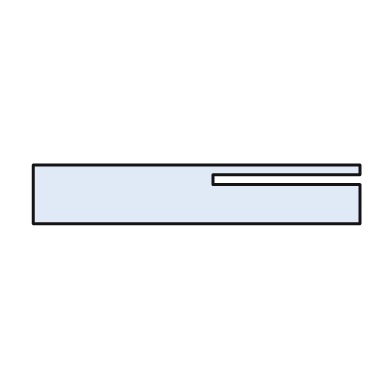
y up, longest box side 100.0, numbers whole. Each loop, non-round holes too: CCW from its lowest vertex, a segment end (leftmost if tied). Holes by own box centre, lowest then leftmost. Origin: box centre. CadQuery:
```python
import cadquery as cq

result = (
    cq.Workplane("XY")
    .moveTo(-50.0, -9.0)
    .lineTo(50.0, -9.0)
    .lineTo(50.0, 3.0)
    .lineTo(5.0, 3.0)
    .lineTo(5.0, 6.0)
    .lineTo(50.0, 6.0)
    .lineTo(50.0, 9.0)
    .lineTo(-50.0, 9.0)
    .close()
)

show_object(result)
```